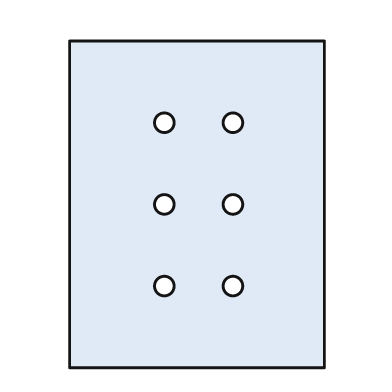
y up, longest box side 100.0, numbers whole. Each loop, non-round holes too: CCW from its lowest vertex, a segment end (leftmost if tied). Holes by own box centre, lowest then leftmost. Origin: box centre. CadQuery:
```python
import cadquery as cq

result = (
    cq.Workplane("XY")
    .moveTo(-39.0, -50.0)
    .lineTo(39.0, -50.0)
    .lineTo(39.0, 50.0)
    .lineTo(-39.0, 50.0)
    .close()
    .moveTo(-10.0, -25.0)
    .circle(3.0)
    .moveTo(11.0, -25.0)
    .circle(3.0)
    .moveTo(-10.0, 0.0)
    .circle(3.0)
    .moveTo(11.0, 0.0)
    .circle(3.0)
    .moveTo(-10.0, 25.0)
    .circle(3.0)
    .moveTo(11.0, 25.0)
    .circle(3.0)
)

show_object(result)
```